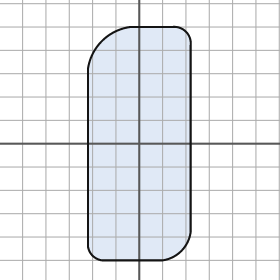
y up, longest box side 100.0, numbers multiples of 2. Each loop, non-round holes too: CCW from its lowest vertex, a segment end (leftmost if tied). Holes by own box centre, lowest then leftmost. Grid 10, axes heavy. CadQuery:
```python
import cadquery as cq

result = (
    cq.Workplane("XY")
    .moveTo(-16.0, -50.0)
    .lineTo(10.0, -50.0)
    .threePointArc((18.0, -46.0), (22.0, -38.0))
    .lineTo(22.0, 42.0)
    .threePointArc((20.0, 48.0), (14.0, 50.0))
    .lineTo(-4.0, 50.0)
    .threePointArc((-16.0, 44.0), (-22.0, 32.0))
    .lineTo(-22.0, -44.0)
    .threePointArc((-20.0, -48.0), (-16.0, -50.0))
    .close()
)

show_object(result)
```